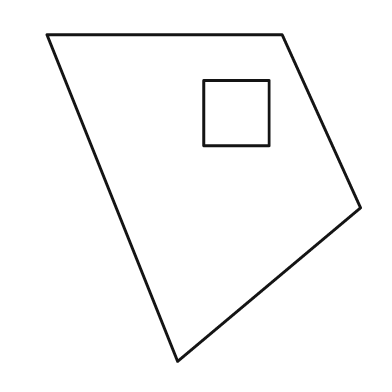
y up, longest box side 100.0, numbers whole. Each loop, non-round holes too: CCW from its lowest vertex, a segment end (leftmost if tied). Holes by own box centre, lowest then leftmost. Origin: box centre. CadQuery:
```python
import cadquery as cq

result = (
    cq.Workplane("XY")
    .moveTo(-8.0, -50.0)
    .lineTo(48.0, -3.0)
    .lineTo(24.0, 50.0)
    .lineTo(-48.0, 50.0)
    .close()
    .moveTo(0.0, 16.0)
    .lineTo(20.0, 16.0)
    .lineTo(20.0, 36.0)
    .lineTo(0.0, 36.0)
    .close()
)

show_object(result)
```